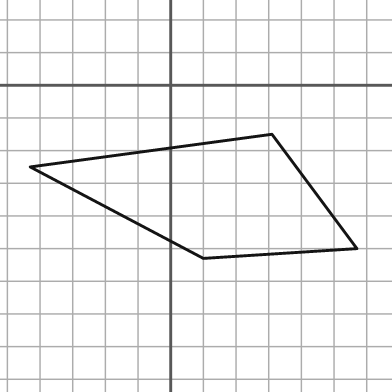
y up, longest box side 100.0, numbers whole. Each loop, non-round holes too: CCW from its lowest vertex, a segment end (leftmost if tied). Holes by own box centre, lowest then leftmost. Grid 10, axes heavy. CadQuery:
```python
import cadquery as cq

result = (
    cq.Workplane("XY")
    .moveTo(10.0, -53.0)
    .lineTo(57.0, -50.0)
    .lineTo(31.0, -15.0)
    .lineTo(-43.0, -25.0)
    .close()
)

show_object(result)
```